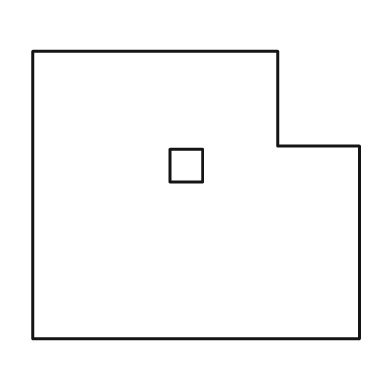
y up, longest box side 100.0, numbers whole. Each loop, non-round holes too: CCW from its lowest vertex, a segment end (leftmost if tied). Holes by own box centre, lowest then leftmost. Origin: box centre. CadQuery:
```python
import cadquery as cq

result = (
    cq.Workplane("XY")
    .moveTo(-50.0, -44.0)
    .lineTo(50.0, -44.0)
    .lineTo(50.0, 15.0)
    .lineTo(25.0, 15.0)
    .lineTo(25.0, 44.0)
    .lineTo(-50.0, 44.0)
    .close()
    .moveTo(-8.0, 4.0)
    .lineTo(2.0, 4.0)
    .lineTo(2.0, 14.0)
    .lineTo(-8.0, 14.0)
    .close()
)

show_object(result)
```